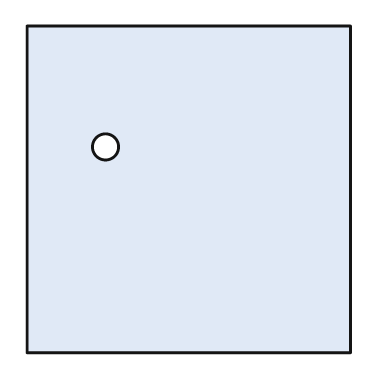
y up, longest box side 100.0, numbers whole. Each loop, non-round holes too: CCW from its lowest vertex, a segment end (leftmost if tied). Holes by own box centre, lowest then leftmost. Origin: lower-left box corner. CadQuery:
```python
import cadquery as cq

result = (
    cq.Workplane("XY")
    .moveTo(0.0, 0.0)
    .lineTo(99.0, 0.0)
    .lineTo(99.0, 100.0)
    .lineTo(0.0, 100.0)
    .close()
    .moveTo(24.0, 63.0)
    .circle(4.0)
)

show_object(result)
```